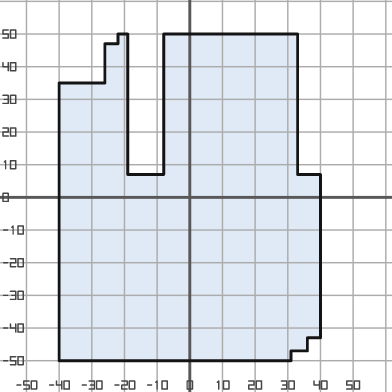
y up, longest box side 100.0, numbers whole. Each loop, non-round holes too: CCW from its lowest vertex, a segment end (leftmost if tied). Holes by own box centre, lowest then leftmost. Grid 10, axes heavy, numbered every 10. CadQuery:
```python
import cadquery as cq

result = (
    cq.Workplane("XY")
    .moveTo(-40.0, -50.0)
    .lineTo(31.0, -50.0)
    .lineTo(31.0, -47.0)
    .lineTo(36.0, -47.0)
    .lineTo(36.0, -43.0)
    .lineTo(40.0, -43.0)
    .lineTo(40.0, 7.0)
    .lineTo(33.0, 7.0)
    .lineTo(33.0, 50.0)
    .lineTo(-8.0, 50.0)
    .lineTo(-8.0, 7.0)
    .lineTo(-19.0, 7.0)
    .lineTo(-19.0, 50.0)
    .lineTo(-22.0, 50.0)
    .lineTo(-22.0, 47.0)
    .lineTo(-26.0, 47.0)
    .lineTo(-26.0, 35.0)
    .lineTo(-40.0, 35.0)
    .close()
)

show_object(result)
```